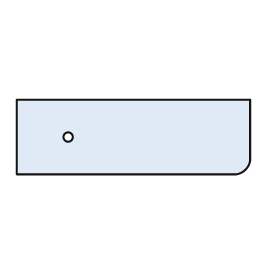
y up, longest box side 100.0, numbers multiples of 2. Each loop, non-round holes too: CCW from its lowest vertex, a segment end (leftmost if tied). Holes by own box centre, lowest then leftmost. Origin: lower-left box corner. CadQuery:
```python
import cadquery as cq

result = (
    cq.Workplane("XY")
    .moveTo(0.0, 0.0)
    .lineTo(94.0, 0.0)
    .threePointArc((98.0, 2.0), (100.0, 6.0))
    .lineTo(100.0, 32.0)
    .lineTo(0.0, 32.0)
    .close()
    .moveTo(22.0, 16.0)
    .circle(2.0)
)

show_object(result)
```